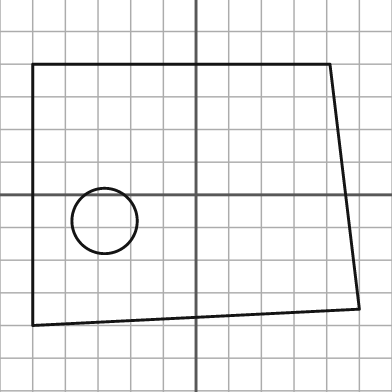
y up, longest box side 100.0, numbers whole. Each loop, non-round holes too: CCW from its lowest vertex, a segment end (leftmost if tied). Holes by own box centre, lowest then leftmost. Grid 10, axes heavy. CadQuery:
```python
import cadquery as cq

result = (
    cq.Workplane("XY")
    .moveTo(-50.0, -40.0)
    .lineTo(50.0, -35.0)
    .lineTo(41.0, 40.0)
    .lineTo(-50.0, 40.0)
    .close()
    .moveTo(-28.0, -8.0)
    .circle(10.0)
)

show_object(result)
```